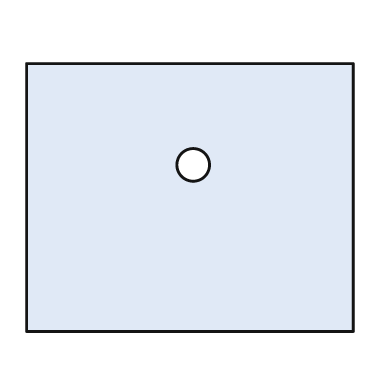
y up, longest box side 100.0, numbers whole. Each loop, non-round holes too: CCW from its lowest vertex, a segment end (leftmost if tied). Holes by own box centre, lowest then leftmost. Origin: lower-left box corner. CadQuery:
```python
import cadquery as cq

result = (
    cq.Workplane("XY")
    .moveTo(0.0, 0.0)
    .lineTo(100.0, 0.0)
    .lineTo(100.0, 82.0)
    .lineTo(0.0, 82.0)
    .close()
    .moveTo(51.0, 51.0)
    .circle(5.0)
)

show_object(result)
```